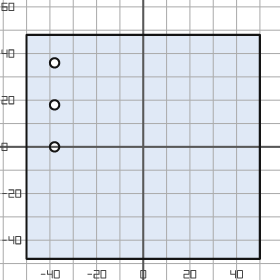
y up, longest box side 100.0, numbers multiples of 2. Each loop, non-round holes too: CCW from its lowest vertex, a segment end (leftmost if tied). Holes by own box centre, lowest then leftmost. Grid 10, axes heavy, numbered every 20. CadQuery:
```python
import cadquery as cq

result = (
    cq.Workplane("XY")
    .moveTo(-50.0, -48.0)
    .lineTo(50.0, -48.0)
    .lineTo(50.0, 48.0)
    .lineTo(-50.0, 48.0)
    .close()
    .moveTo(-38.0, 0.0)
    .circle(2.0)
    .moveTo(-38.0, 18.0)
    .circle(2.0)
    .moveTo(-38.0, 36.0)
    .circle(2.0)
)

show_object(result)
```